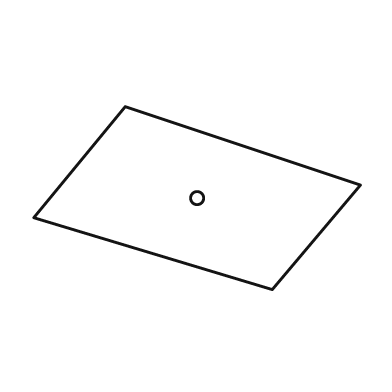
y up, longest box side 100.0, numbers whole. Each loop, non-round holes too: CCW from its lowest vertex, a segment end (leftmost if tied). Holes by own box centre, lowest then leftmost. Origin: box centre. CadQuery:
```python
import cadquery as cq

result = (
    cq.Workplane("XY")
    .moveTo(23.0, -28.0)
    .lineTo(50.0, 4.0)
    .lineTo(-22.0, 28.0)
    .lineTo(-50.0, -6.0)
    .close()
    .moveTo(0.0, 0.0)
    .circle(2.0)
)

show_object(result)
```